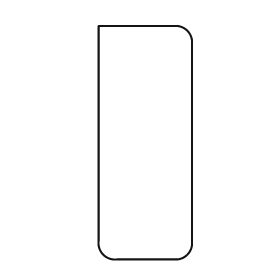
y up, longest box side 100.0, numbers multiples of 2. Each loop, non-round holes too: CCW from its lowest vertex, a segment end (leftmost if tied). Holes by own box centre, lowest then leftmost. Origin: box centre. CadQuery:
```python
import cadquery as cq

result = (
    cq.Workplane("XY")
    .moveTo(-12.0, -50.0)
    .lineTo(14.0, -50.0)
    .threePointArc((18.0, -48.0), (20.0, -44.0))
    .lineTo(20.0, 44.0)
    .threePointArc((18.0, 48.0), (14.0, 50.0))
    .lineTo(-20.0, 50.0)
    .lineTo(-20.0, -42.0)
    .threePointArc((-18.0, -48.0), (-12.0, -50.0))
    .close()
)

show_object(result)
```